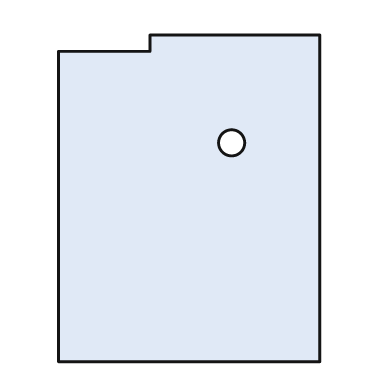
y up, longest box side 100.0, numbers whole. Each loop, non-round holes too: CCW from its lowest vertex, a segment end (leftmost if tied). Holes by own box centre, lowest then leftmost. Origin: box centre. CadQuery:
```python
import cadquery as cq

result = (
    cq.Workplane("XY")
    .moveTo(-40.0, -50.0)
    .lineTo(40.0, -50.0)
    .lineTo(40.0, 50.0)
    .lineTo(-12.0, 50.0)
    .lineTo(-12.0, 45.0)
    .lineTo(-40.0, 45.0)
    .close()
    .moveTo(13.0, 17.0)
    .circle(4.0)
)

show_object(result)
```